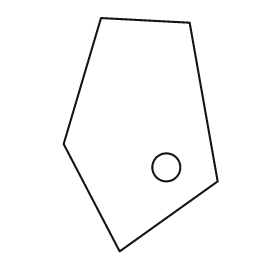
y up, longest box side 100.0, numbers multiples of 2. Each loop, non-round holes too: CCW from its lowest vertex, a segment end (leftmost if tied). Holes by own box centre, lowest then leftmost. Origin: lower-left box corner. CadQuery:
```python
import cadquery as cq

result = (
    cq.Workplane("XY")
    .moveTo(24.0, 0.0)
    .lineTo(66.0, 30.0)
    .lineTo(54.0, 98.0)
    .lineTo(16.0, 100.0)
    .lineTo(0.0, 46.0)
    .close()
    .moveTo(44.0, 36.0)
    .circle(6.0)
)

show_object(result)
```